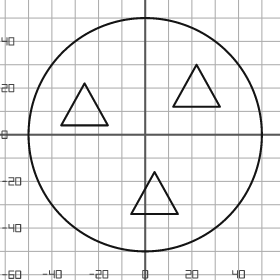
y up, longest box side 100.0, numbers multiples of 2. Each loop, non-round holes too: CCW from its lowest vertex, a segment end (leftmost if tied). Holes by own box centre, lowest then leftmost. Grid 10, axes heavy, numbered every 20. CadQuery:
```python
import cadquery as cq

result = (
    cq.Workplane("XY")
    .moveTo(0.0, 0.0)
    .circle(50.0)
    .moveTo(-6.0, -34.0)
    .lineTo(14.0, -34.0)
    .lineTo(4.0, -16.0)
    .close()
    .moveTo(-36.0, 4.0)
    .lineTo(-16.0, 4.0)
    .lineTo(-26.0, 22.0)
    .close()
    .moveTo(12.0, 12.0)
    .lineTo(32.0, 12.0)
    .lineTo(22.0, 30.0)
    .close()
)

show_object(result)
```